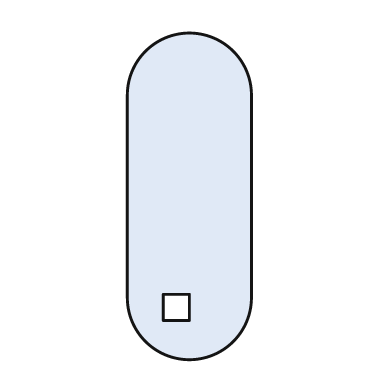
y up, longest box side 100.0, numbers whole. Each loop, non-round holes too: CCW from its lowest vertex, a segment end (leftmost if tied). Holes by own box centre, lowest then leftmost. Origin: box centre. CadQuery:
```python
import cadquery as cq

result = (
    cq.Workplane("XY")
    .moveTo(-19.0, -31.0)
    .threePointArc((0.0, -50.0), (19.0, -31.0))
    .lineTo(19.0, 31.0)
    .threePointArc((0.0, 50.0), (-19.0, 31.0))
    .close()
    .moveTo(-8.0, -38.0)
    .lineTo(0.0, -38.0)
    .lineTo(0.0, -30.0)
    .lineTo(-8.0, -30.0)
    .close()
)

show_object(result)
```